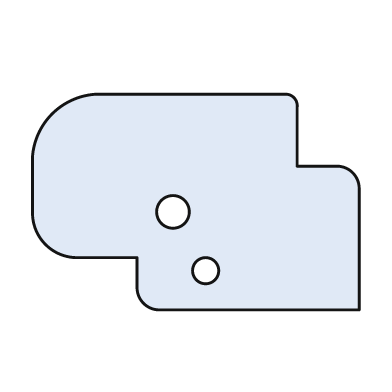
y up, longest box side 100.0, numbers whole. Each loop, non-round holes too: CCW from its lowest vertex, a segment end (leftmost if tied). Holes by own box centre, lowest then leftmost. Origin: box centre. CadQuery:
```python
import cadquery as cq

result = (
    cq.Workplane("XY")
    .moveTo(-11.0, -33.0)
    .lineTo(50.0, -33.0)
    .lineTo(50.0, 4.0)
    .threePointArc((48.0, 9.0), (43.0, 11.0))
    .lineTo(31.0, 11.0)
    .lineTo(31.0, 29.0)
    .threePointArc((30.0, 32.0), (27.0, 33.0))
    .lineTo(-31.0, 33.0)
    .threePointArc((-44.0, 27.0), (-50.0, 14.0))
    .lineTo(-50.0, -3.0)
    .threePointArc((-46.0, -13.0), (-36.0, -17.0))
    .lineTo(-18.0, -17.0)
    .lineTo(-18.0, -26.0)
    .threePointArc((-16.0, -31.0), (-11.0, -33.0))
    .close()
    .moveTo(3.0, -21.0)
    .circle(4.0)
    .moveTo(-7.0, -3.0)
    .circle(5.0)
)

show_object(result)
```